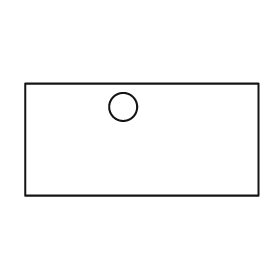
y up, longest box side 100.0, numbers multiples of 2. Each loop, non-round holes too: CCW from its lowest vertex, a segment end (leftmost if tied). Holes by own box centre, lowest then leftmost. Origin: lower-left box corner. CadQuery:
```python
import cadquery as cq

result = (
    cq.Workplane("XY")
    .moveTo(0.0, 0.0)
    .lineTo(100.0, 0.0)
    .lineTo(100.0, 48.0)
    .lineTo(0.0, 48.0)
    .close()
    .moveTo(42.0, 38.0)
    .circle(6.0)
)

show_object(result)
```